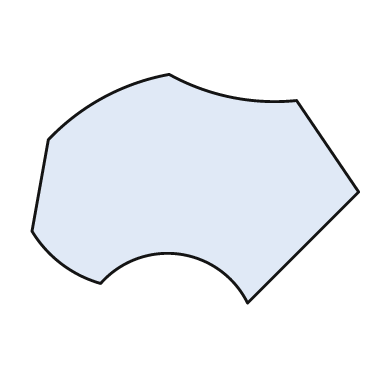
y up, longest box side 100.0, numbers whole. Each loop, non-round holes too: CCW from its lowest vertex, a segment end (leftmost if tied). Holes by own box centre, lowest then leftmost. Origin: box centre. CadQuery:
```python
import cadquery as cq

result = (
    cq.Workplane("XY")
    .moveTo(16.0, -35.0)
    .lineTo(50.0, -1.0)
    .lineTo(31.0, 27.0)
    .threePointArc((11.0, 28.0), (-8.0, 35.0))
    .threePointArc((-28.0, 28.0), (-45.0, 15.0))
    .lineTo(-50.0, -13.0)
    .threePointArc((-41.0, -23.0), (-29.0, -29.0))
    .threePointArc((-5.0, -20.0), (16.0, -35.0))
    .close()
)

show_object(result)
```